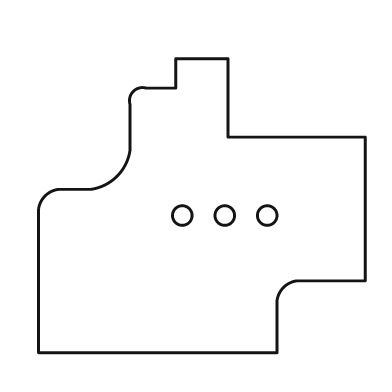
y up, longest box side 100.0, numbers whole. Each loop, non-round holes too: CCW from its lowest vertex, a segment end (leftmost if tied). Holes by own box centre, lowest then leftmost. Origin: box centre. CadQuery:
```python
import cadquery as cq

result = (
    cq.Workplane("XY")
    .moveTo(-50.0, -45.0)
    .lineTo(23.0, -45.0)
    .lineTo(23.0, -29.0)
    .threePointArc((25.0, -25.0), (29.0, -23.0))
    .lineTo(50.0, -23.0)
    .lineTo(50.0, 21.0)
    .lineTo(8.0, 21.0)
    .lineTo(8.0, 45.0)
    .lineTo(-8.0, 45.0)
    .lineTo(-8.0, 36.0)
    .lineTo(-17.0, 36.0)
    .threePointArc((-21.0, 35.0), (-22.0, 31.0))
    .lineTo(-22.0, 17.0)
    .threePointArc((-26.0, 9.0), (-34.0, 5.0))
    .lineTo(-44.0, 5.0)
    .threePointArc((-48.0, 3.0), (-50.0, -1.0))
    .close()
    .moveTo(-6.0, -3.0)
    .circle(3.0)
    .moveTo(7.0, -3.0)
    .circle(3.0)
    .moveTo(20.0, -3.0)
    .circle(3.0)
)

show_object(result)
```